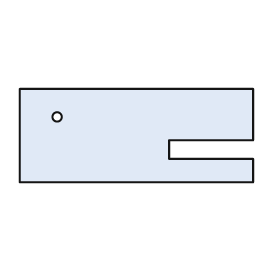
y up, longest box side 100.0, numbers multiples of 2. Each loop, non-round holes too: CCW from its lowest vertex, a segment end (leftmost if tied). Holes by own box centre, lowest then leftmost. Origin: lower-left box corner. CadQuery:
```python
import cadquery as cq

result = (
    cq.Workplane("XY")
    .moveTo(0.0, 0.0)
    .lineTo(100.0, 0.0)
    .lineTo(100.0, 10.0)
    .lineTo(64.0, 10.0)
    .lineTo(64.0, 18.0)
    .lineTo(100.0, 18.0)
    .lineTo(100.0, 40.0)
    .lineTo(0.0, 40.0)
    .close()
    .moveTo(16.0, 28.0)
    .circle(2.0)
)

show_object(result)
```